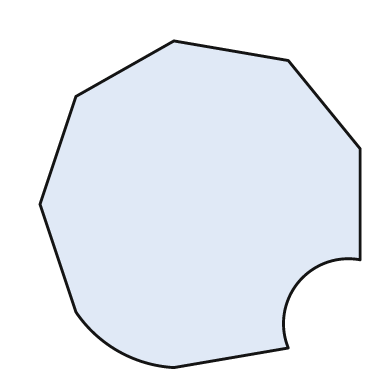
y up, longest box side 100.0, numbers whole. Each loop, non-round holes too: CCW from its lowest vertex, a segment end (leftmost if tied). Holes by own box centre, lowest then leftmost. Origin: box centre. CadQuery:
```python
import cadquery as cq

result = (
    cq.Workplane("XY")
    .moveTo(-8.0, -50.0)
    .lineTo(27.0, -44.0)
    .threePointArc((30.0, -24.0), (49.0, -17.0))
    .lineTo(49.0, 17.0)
    .lineTo(27.0, 44.0)
    .lineTo(-8.0, 50.0)
    .lineTo(-38.0, 33.0)
    .lineTo(-49.0, 0.0)
    .lineTo(-38.0, -33.0)
    .threePointArc((-25.0, -45.0), (-8.0, -50.0))
    .close()
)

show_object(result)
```